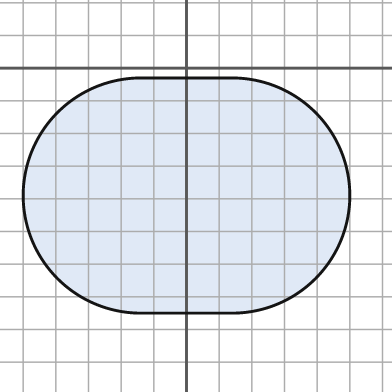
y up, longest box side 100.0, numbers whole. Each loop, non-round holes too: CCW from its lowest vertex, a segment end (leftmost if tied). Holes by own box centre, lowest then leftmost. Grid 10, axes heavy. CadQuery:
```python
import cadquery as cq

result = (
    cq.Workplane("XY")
    .moveTo(-14.0, -75.0)
    .lineTo(14.0, -75.0)
    .threePointArc((50.0, -39.0), (14.0, -3.0))
    .lineTo(-14.0, -3.0)
    .threePointArc((-50.0, -39.0), (-14.0, -75.0))
    .close()
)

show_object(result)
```